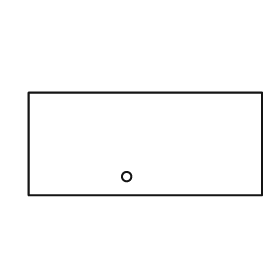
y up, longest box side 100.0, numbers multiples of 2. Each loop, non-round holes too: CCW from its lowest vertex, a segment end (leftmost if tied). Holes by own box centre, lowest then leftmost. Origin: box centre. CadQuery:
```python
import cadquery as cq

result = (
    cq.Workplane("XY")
    .moveTo(-50.0, -22.0)
    .lineTo(50.0, -22.0)
    .lineTo(50.0, 22.0)
    .lineTo(-50.0, 22.0)
    .close()
    .moveTo(-8.0, -14.0)
    .circle(2.0)
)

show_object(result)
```